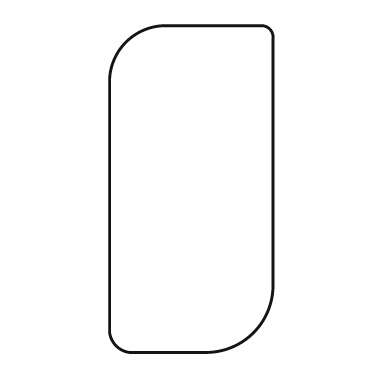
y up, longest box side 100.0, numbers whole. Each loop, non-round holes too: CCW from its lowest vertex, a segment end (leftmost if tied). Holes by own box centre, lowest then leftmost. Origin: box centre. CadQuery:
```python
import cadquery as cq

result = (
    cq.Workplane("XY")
    .moveTo(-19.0, -50.0)
    .lineTo(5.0, -50.0)
    .threePointArc((19.0, -44.0), (25.0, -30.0))
    .lineTo(25.0, 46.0)
    .threePointArc((24.0, 49.0), (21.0, 50.0))
    .lineTo(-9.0, 50.0)
    .threePointArc((-20.0, 45.0), (-25.0, 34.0))
    .lineTo(-25.0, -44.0)
    .threePointArc((-23.0, -48.0), (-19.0, -50.0))
    .close()
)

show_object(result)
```